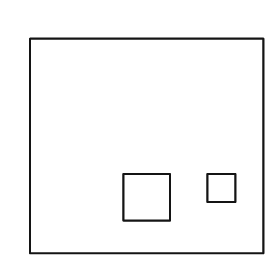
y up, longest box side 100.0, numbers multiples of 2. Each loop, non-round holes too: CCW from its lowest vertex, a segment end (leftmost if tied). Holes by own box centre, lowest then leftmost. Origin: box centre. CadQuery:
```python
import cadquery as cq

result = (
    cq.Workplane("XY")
    .moveTo(-50.0, -46.0)
    .lineTo(50.0, -46.0)
    .lineTo(50.0, 46.0)
    .lineTo(-50.0, 46.0)
    .close()
    .moveTo(-10.0, -32.0)
    .lineTo(10.0, -32.0)
    .lineTo(10.0, -12.0)
    .lineTo(-10.0, -12.0)
    .close()
    .moveTo(26.0, -24.0)
    .lineTo(38.0, -24.0)
    .lineTo(38.0, -12.0)
    .lineTo(26.0, -12.0)
    .close()
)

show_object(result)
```